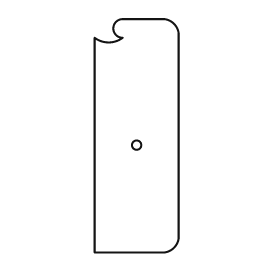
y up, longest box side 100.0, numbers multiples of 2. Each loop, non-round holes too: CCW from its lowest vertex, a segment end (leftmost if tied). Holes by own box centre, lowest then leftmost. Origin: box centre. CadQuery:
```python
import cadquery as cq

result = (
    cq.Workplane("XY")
    .moveTo(-18.0, -50.0)
    .lineTo(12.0, -50.0)
    .threePointArc((16.0, -48.0), (18.0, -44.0))
    .lineTo(18.0, 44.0)
    .threePointArc((16.0, 48.0), (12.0, 50.0))
    .lineTo(-6.0, 50.0)
    .threePointArc((-10.0, 46.0), (-6.0, 42.0))
    .threePointArc((-12.0, 40.0), (-18.0, 42.0))
    .close()
    .moveTo(0.0, -4.0)
    .circle(2.0)
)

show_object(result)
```